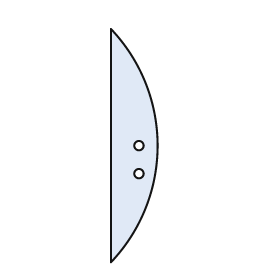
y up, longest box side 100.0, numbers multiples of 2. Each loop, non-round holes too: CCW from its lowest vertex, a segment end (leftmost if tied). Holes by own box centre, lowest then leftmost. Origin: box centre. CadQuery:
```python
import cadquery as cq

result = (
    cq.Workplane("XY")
    .moveTo(-10.0, -50.0)
    .threePointArc((10.0, 0.0), (-10.0, 50.0))
    .close()
    .moveTo(2.0, -12.0)
    .circle(2.0)
    .moveTo(2.0, 0.0)
    .circle(2.0)
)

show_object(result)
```